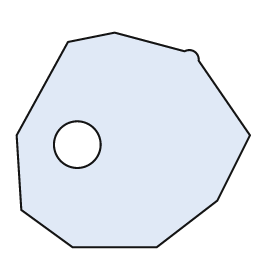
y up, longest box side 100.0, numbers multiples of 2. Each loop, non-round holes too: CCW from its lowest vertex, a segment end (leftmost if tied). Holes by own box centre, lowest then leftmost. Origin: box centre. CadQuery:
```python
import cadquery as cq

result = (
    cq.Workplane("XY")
    .moveTo(-26.0, -46.0)
    .lineTo(10.0, -46.0)
    .lineTo(36.0, -26.0)
    .lineTo(50.0, 2.0)
    .lineTo(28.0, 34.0)
    .threePointArc((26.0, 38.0), (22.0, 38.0))
    .lineTo(-8.0, 46.0)
    .lineTo(-28.0, 42.0)
    .lineTo(-50.0, 2.0)
    .lineTo(-48.0, -30.0)
    .close()
    .moveTo(-24.0, -2.0)
    .circle(10.0)
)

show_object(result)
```